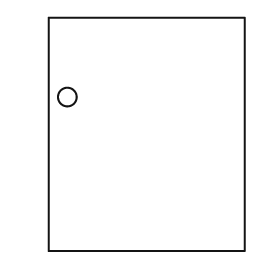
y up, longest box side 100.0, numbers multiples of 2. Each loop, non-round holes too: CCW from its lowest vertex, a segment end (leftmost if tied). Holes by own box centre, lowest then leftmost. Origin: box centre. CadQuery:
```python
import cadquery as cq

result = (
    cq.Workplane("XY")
    .moveTo(-42.0, -50.0)
    .lineTo(42.0, -50.0)
    .lineTo(42.0, 50.0)
    .lineTo(-42.0, 50.0)
    .close()
    .moveTo(-34.0, 16.0)
    .circle(4.0)
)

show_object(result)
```